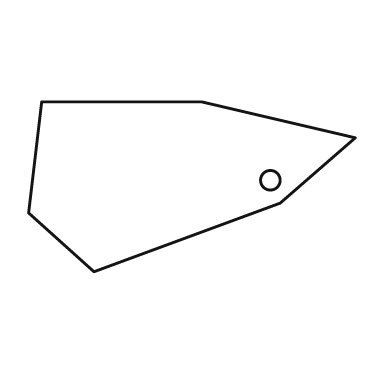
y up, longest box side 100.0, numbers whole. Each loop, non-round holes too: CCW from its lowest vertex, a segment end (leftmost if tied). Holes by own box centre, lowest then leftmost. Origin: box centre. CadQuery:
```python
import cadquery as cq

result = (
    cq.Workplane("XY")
    .moveTo(-30.0, -26.0)
    .lineTo(27.0, -5.0)
    .lineTo(50.0, 15.0)
    .lineTo(3.0, 26.0)
    .lineTo(-46.0, 26.0)
    .lineTo(-50.0, -8.0)
    .close()
    .moveTo(24.0, 2.0)
    .circle(3.0)
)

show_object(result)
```